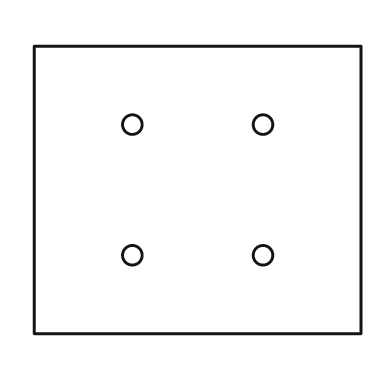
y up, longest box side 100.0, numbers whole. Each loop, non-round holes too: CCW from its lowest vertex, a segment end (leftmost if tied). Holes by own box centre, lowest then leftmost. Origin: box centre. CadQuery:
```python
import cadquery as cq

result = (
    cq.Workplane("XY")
    .moveTo(-50.0, -44.0)
    .lineTo(50.0, -44.0)
    .lineTo(50.0, 44.0)
    .lineTo(-50.0, 44.0)
    .close()
    .moveTo(-20.0, -20.0)
    .circle(3.0)
    .moveTo(20.0, -20.0)
    .circle(3.0)
    .moveTo(-20.0, 20.0)
    .circle(3.0)
    .moveTo(20.0, 20.0)
    .circle(3.0)
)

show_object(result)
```